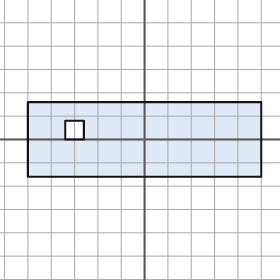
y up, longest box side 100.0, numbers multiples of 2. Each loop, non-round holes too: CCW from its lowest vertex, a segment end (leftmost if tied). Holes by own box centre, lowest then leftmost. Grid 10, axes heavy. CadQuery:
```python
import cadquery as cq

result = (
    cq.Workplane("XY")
    .moveTo(-50.0, -16.0)
    .lineTo(50.0, -16.0)
    .lineTo(50.0, 16.0)
    .lineTo(-50.0, 16.0)
    .close()
    .moveTo(-34.0, 0.0)
    .lineTo(-26.0, 0.0)
    .lineTo(-26.0, 8.0)
    .lineTo(-34.0, 8.0)
    .close()
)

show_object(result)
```